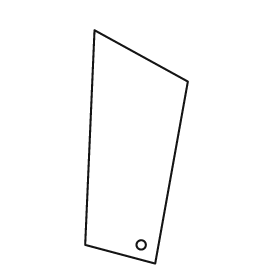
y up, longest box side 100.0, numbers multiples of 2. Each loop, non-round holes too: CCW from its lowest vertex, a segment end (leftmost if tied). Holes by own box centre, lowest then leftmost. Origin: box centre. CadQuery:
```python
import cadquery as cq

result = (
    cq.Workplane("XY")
    .moveTo(8.0, -50.0)
    .lineTo(22.0, 28.0)
    .lineTo(-18.0, 50.0)
    .lineTo(-22.0, -42.0)
    .close()
    .moveTo(2.0, -42.0)
    .circle(2.0)
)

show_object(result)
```